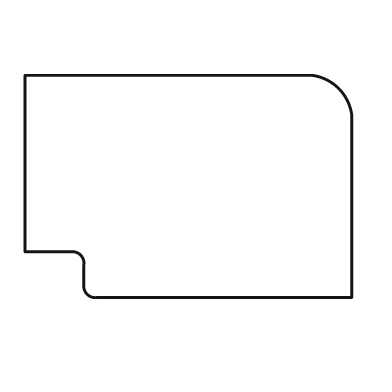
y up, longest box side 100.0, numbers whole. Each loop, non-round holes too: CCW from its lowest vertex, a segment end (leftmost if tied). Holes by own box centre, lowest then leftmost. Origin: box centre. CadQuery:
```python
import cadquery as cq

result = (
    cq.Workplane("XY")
    .moveTo(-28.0, -34.0)
    .lineTo(50.0, -34.0)
    .lineTo(50.0, 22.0)
    .threePointArc((46.0, 30.0), (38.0, 34.0))
    .lineTo(-50.0, 34.0)
    .lineTo(-50.0, -20.0)
    .lineTo(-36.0, -20.0)
    .threePointArc((-33.0, -21.0), (-32.0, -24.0))
    .lineTo(-32.0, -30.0)
    .threePointArc((-31.0, -33.0), (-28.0, -34.0))
    .close()
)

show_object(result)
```